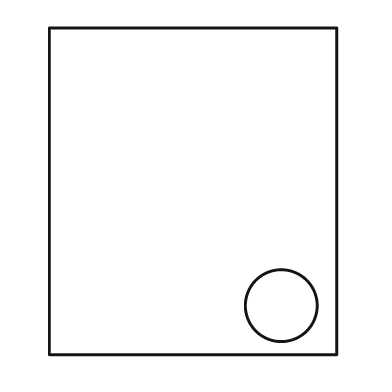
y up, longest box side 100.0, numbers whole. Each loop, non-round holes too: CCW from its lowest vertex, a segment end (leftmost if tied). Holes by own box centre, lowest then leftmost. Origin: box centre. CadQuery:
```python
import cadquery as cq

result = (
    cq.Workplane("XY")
    .moveTo(-44.0, -50.0)
    .lineTo(44.0, -50.0)
    .lineTo(44.0, 50.0)
    .lineTo(-44.0, 50.0)
    .close()
    .moveTo(27.0, -35.0)
    .circle(11.0)
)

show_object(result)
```